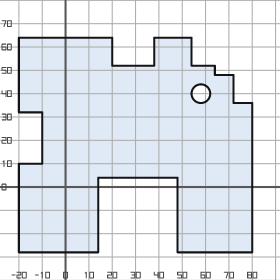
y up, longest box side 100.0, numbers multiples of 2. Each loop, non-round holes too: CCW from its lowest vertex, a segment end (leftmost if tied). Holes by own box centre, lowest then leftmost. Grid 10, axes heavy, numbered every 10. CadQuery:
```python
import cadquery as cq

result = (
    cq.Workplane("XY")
    .moveTo(-20.0, -28.0)
    .lineTo(14.0, -28.0)
    .lineTo(14.0, 4.0)
    .lineTo(48.0, 4.0)
    .lineTo(48.0, -28.0)
    .lineTo(80.0, -28.0)
    .lineTo(80.0, 36.0)
    .lineTo(72.0, 36.0)
    .lineTo(72.0, 48.0)
    .lineTo(64.0, 48.0)
    .lineTo(64.0, 52.0)
    .lineTo(54.0, 52.0)
    .lineTo(54.0, 64.0)
    .lineTo(38.0, 64.0)
    .lineTo(38.0, 52.0)
    .lineTo(20.0, 52.0)
    .lineTo(20.0, 64.0)
    .lineTo(-20.0, 64.0)
    .lineTo(-20.0, 32.0)
    .lineTo(-10.0, 32.0)
    .lineTo(-10.0, 10.0)
    .lineTo(-20.0, 10.0)
    .close()
    .moveTo(58.0, 40.0)
    .circle(4.0)
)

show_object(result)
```